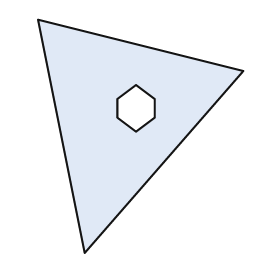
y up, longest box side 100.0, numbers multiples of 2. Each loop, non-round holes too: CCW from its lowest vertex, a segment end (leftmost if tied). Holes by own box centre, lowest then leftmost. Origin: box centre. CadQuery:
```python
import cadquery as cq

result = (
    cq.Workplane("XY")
    .moveTo(-24.0, -50.0)
    .lineTo(44.0, 28.0)
    .lineTo(-44.0, 50.0)
    .close()
    .moveTo(-2.0, 2.0)
    .lineTo(6.0, 8.0)
    .lineTo(6.0, 16.0)
    .lineTo(-2.0, 22.0)
    .lineTo(-10.0, 16.0)
    .lineTo(-10.0, 8.0)
    .close()
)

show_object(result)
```